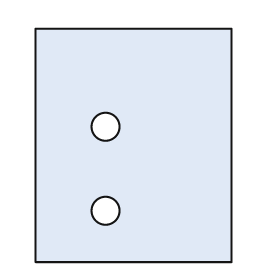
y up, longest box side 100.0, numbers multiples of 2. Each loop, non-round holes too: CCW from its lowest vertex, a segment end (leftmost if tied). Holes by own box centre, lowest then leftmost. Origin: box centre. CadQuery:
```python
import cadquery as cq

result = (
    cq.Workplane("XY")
    .moveTo(-42.0, -50.0)
    .lineTo(42.0, -50.0)
    .lineTo(42.0, 50.0)
    .lineTo(-42.0, 50.0)
    .close()
    .moveTo(-12.0, -28.0)
    .circle(6.0)
    .moveTo(-12.0, 8.0)
    .circle(6.0)
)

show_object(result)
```